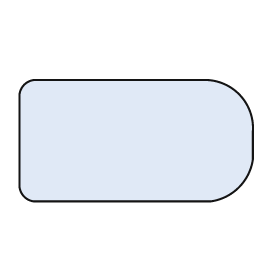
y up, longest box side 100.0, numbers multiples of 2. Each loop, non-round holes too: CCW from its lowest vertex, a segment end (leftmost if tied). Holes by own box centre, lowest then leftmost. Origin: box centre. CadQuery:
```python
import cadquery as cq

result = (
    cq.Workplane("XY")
    .moveTo(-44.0, -26.0)
    .lineTo(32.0, -26.0)
    .threePointArc((44.0, -20.0), (50.0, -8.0))
    .lineTo(50.0, 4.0)
    .threePointArc((44.0, 20.0), (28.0, 26.0))
    .lineTo(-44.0, 26.0)
    .threePointArc((-48.0, 24.0), (-50.0, 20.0))
    .lineTo(-50.0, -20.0)
    .threePointArc((-48.0, -24.0), (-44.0, -26.0))
    .close()
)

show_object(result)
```